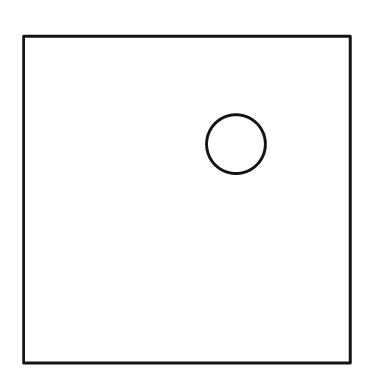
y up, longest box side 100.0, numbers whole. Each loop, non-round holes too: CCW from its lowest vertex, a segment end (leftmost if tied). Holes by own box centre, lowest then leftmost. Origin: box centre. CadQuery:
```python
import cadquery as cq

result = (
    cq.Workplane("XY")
    .moveTo(-50.0, -50.0)
    .lineTo(50.0, -50.0)
    .lineTo(50.0, 50.0)
    .lineTo(-50.0, 50.0)
    .close()
    .moveTo(15.0, 17.0)
    .circle(9.0)
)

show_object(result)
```